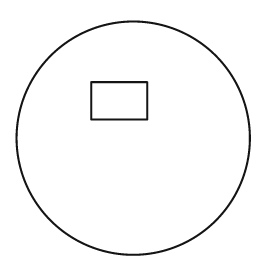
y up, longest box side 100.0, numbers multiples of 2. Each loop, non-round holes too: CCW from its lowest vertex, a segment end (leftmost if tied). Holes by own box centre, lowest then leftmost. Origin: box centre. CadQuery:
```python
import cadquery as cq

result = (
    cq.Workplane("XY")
    .moveTo(0.0, 0.0)
    .circle(50.0)
    .moveTo(-18.0, 8.0)
    .lineTo(6.0, 8.0)
    .lineTo(6.0, 24.0)
    .lineTo(-18.0, 24.0)
    .close()
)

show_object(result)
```